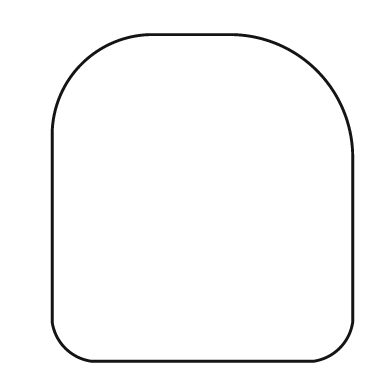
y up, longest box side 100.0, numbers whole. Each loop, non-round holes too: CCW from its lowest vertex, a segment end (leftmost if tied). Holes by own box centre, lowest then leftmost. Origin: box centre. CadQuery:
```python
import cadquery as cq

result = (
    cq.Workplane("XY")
    .moveTo(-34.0, -50.0)
    .lineTo(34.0, -50.0)
    .threePointArc((42.0, -46.0), (46.0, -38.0))
    .lineTo(46.0, 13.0)
    .threePointArc((35.0, 39.0), (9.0, 50.0))
    .lineTo(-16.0, 50.0)
    .threePointArc((-37.0, 41.0), (-46.0, 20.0))
    .lineTo(-46.0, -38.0)
    .threePointArc((-42.0, -46.0), (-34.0, -50.0))
    .close()
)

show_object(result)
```